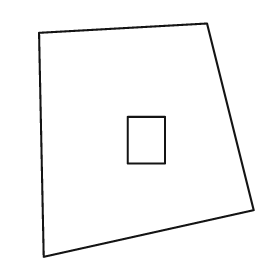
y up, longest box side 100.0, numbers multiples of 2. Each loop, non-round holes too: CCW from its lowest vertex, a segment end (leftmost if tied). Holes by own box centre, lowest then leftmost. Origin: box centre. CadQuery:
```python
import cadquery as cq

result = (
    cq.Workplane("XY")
    .moveTo(-44.0, -50.0)
    .lineTo(46.0, -30.0)
    .lineTo(26.0, 50.0)
    .lineTo(-46.0, 46.0)
    .close()
    .moveTo(-8.0, -10.0)
    .lineTo(8.0, -10.0)
    .lineTo(8.0, 10.0)
    .lineTo(-8.0, 10.0)
    .close()
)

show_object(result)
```